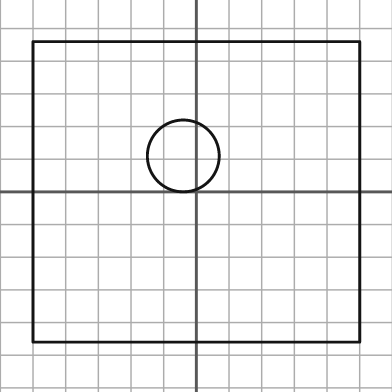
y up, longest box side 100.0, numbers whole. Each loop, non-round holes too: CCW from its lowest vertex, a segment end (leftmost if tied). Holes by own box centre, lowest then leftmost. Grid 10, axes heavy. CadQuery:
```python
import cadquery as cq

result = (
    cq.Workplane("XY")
    .moveTo(-50.0, -46.0)
    .lineTo(50.0, -46.0)
    .lineTo(50.0, 46.0)
    .lineTo(-50.0, 46.0)
    .close()
    .moveTo(-4.0, 11.0)
    .circle(11.0)
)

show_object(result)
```